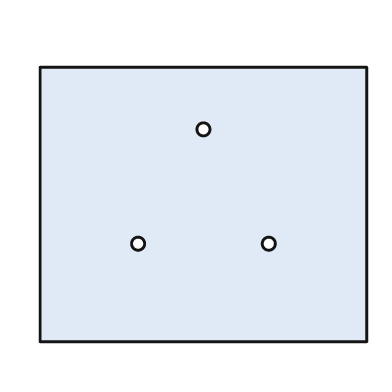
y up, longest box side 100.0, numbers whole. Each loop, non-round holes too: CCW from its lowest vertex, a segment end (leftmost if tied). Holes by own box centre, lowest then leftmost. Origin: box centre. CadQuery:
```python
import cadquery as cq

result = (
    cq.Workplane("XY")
    .moveTo(-50.0, -42.0)
    .lineTo(50.0, -42.0)
    .lineTo(50.0, 42.0)
    .lineTo(-50.0, 42.0)
    .close()
    .moveTo(-20.0, -12.0)
    .circle(2.0)
    .moveTo(20.0, -12.0)
    .circle(2.0)
    .moveTo(0.0, 23.0)
    .circle(2.0)
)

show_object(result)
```